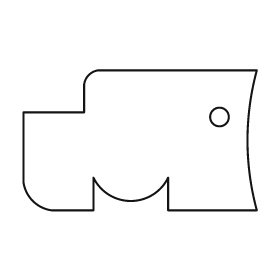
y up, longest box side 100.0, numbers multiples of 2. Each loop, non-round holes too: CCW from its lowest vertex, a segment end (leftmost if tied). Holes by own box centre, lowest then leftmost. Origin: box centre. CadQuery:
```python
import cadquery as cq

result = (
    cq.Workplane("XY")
    .moveTo(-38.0, -30.0)
    .lineTo(-20.0, -30.0)
    .lineTo(-20.0, -16.0)
    .threePointArc((-4.0, -26.0), (12.0, -16.0))
    .lineTo(12.0, -30.0)
    .lineTo(50.0, -30.0)
    .threePointArc((46.0, 0.0), (50.0, 30.0))
    .lineTo(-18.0, 30.0)
    .threePointArc((-22.0, 28.0), (-24.0, 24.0))
    .lineTo(-24.0, 12.0)
    .lineTo(-50.0, 12.0)
    .lineTo(-50.0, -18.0)
    .threePointArc((-46.0, -26.0), (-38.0, -30.0))
    .close()
    .moveTo(34.0, 10.0)
    .circle(4.0)
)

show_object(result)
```